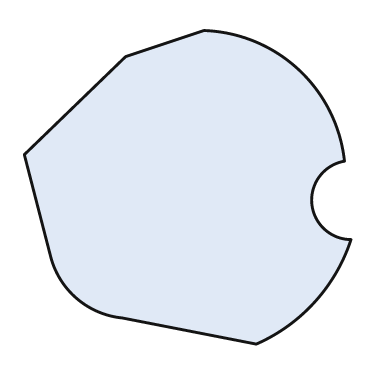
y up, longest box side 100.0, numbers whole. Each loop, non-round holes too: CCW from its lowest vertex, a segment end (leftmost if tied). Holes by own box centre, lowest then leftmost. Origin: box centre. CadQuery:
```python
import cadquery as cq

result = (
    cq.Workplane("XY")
    .moveTo(21.0, -48.0)
    .threePointArc((39.0, -35.0), (50.0, -16.0))
    .threePointArc((38.0, -5.0), (48.0, 8.0))
    .threePointArc((34.0, 36.0), (5.0, 48.0))
    .lineTo(-19.0, 40.0)
    .lineTo(-50.0, 10.0)
    .lineTo(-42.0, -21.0)
    .threePointArc((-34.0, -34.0), (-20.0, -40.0))
    .close()
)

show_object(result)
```